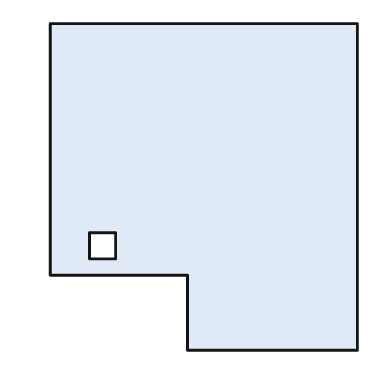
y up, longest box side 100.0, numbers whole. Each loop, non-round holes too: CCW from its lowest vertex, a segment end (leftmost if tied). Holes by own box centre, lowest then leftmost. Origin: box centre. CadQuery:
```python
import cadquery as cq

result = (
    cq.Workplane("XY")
    .moveTo(-5.0, -50.0)
    .lineTo(47.0, -50.0)
    .lineTo(47.0, 50.0)
    .lineTo(-47.0, 50.0)
    .lineTo(-47.0, -27.0)
    .lineTo(-5.0, -27.0)
    .close()
    .moveTo(-35.0, -22.0)
    .lineTo(-27.0, -22.0)
    .lineTo(-27.0, -14.0)
    .lineTo(-35.0, -14.0)
    .close()
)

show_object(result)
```